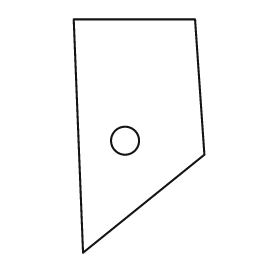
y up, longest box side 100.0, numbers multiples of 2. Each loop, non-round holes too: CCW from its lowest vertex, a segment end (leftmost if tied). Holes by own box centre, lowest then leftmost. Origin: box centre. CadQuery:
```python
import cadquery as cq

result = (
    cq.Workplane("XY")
    .moveTo(-24.0, -50.0)
    .lineTo(28.0, -8.0)
    .lineTo(24.0, 50.0)
    .lineTo(-28.0, 50.0)
    .close()
    .moveTo(-6.0, -2.0)
    .circle(6.0)
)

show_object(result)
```